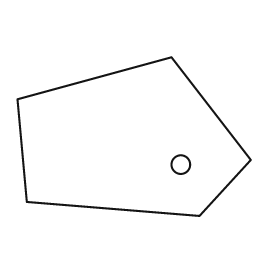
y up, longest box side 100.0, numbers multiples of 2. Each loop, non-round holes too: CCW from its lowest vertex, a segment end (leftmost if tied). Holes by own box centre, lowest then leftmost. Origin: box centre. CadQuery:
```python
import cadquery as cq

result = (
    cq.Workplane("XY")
    .moveTo(28.0, -34.0)
    .lineTo(50.0, -10.0)
    .lineTo(16.0, 34.0)
    .lineTo(-50.0, 16.0)
    .lineTo(-46.0, -28.0)
    .close()
    .moveTo(20.0, -12.0)
    .circle(4.0)
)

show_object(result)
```